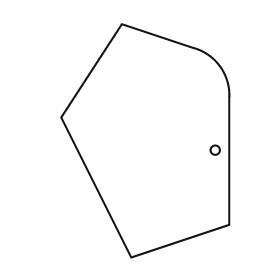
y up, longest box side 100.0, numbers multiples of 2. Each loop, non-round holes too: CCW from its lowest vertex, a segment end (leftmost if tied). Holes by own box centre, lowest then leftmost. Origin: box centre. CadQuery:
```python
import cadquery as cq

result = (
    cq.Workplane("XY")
    .moveTo(-6.0, -50.0)
    .lineTo(36.0, -36.0)
    .lineTo(36.0, 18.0)
    .threePointArc((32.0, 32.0), (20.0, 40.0))
    .lineTo(-10.0, 50.0)
    .lineTo(-36.0, 10.0)
    .close()
    .moveTo(30.0, -4.0)
    .circle(2.0)
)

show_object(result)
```